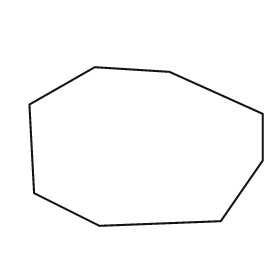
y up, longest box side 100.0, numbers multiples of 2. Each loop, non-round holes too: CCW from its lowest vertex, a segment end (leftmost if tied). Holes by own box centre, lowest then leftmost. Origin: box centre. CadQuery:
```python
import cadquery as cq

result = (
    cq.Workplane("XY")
    .moveTo(-20.0, -34.0)
    .lineTo(32.0, -32.0)
    .lineTo(50.0, -6.0)
    .lineTo(50.0, 14.0)
    .lineTo(10.0, 32.0)
    .lineTo(-22.0, 34.0)
    .lineTo(-50.0, 18.0)
    .lineTo(-48.0, -20.0)
    .close()
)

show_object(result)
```